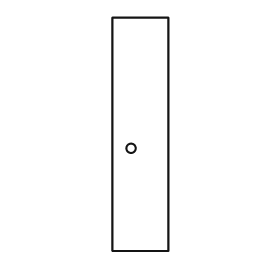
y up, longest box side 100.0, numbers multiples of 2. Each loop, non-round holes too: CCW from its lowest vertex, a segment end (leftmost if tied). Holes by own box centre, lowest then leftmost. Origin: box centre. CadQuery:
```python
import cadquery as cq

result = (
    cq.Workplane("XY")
    .moveTo(-12.0, -50.0)
    .lineTo(12.0, -50.0)
    .lineTo(12.0, 50.0)
    .lineTo(-12.0, 50.0)
    .close()
    .moveTo(-4.0, -6.0)
    .circle(2.0)
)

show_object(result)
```